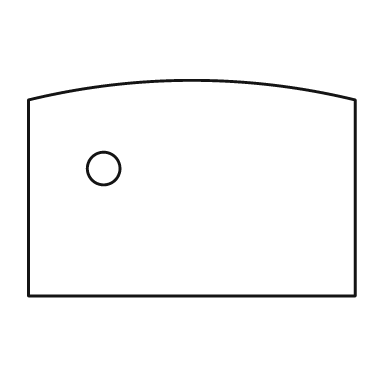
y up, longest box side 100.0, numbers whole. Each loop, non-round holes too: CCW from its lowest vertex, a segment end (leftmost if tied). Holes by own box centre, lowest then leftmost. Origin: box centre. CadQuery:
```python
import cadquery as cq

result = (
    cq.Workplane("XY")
    .moveTo(-50.0, -33.0)
    .lineTo(50.0, -33.0)
    .lineTo(50.0, 27.0)
    .threePointArc((0.0, 33.0), (-50.0, 27.0))
    .close()
    .moveTo(-27.0, 6.0)
    .circle(5.0)
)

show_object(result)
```